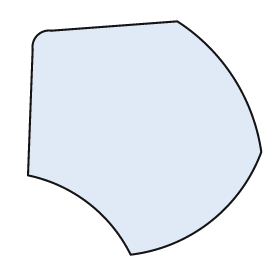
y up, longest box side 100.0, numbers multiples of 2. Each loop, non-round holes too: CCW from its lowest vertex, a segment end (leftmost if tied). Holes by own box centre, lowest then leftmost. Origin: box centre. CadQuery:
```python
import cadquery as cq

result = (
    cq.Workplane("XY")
    .moveTo(-6.0, -50.0)
    .threePointArc((28.0, -36.0), (50.0, -6.0))
    .threePointArc((38.0, 26.0), (14.0, 50.0))
    .lineTo(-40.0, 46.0)
    .threePointArc((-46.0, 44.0), (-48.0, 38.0))
    .lineTo(-50.0, -16.0)
    .threePointArc((-24.0, -28.0), (-6.0, -50.0))
    .close()
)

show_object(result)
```